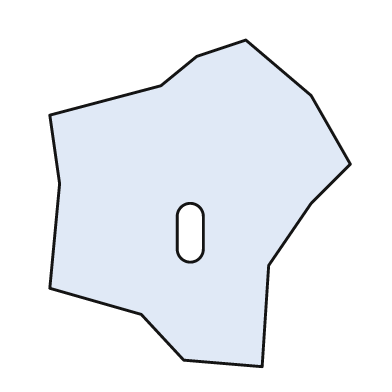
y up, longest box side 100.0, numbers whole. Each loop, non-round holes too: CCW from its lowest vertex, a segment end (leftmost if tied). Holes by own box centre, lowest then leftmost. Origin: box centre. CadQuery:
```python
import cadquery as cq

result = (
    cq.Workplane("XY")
    .moveTo(19.0, -50.0)
    .lineTo(21.0, -19.0)
    .lineTo(34.0, 0.0)
    .lineTo(46.0, 12.0)
    .lineTo(34.0, 33.0)
    .lineTo(14.0, 50.0)
    .lineTo(-1.0, 45.0)
    .lineTo(-12.0, 36.0)
    .lineTo(-46.0, 27.0)
    .lineTo(-43.0, 6.0)
    .lineTo(-46.0, -26.0)
    .lineTo(-18.0, -34.0)
    .lineTo(-5.0, -48.0)
    .close()
    .moveTo(-7.0, -14.0)
    .threePointArc((-3.0, -18.0), (1.0, -14.0))
    .lineTo(1.0, -4.0)
    .threePointArc((-3.0, 0.0), (-7.0, -4.0))
    .close()
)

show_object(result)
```